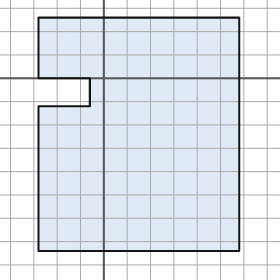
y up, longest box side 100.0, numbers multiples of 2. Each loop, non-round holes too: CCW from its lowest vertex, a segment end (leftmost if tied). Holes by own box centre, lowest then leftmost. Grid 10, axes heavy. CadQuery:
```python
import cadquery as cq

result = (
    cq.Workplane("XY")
    .moveTo(-28.0, -74.0)
    .lineTo(58.0, -74.0)
    .lineTo(58.0, 26.0)
    .lineTo(-28.0, 26.0)
    .lineTo(-28.0, 0.0)
    .lineTo(-6.0, 0.0)
    .lineTo(-6.0, -12.0)
    .lineTo(-28.0, -12.0)
    .close()
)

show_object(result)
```